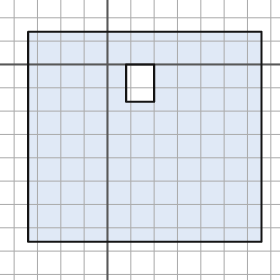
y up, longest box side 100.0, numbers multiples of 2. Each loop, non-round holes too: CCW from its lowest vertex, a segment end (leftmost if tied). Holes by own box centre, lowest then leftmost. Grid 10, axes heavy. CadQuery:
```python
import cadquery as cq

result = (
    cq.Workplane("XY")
    .moveTo(-34.0, -76.0)
    .lineTo(66.0, -76.0)
    .lineTo(66.0, 14.0)
    .lineTo(-34.0, 14.0)
    .close()
    .moveTo(8.0, -16.0)
    .lineTo(20.0, -16.0)
    .lineTo(20.0, 0.0)
    .lineTo(8.0, 0.0)
    .close()
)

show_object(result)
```